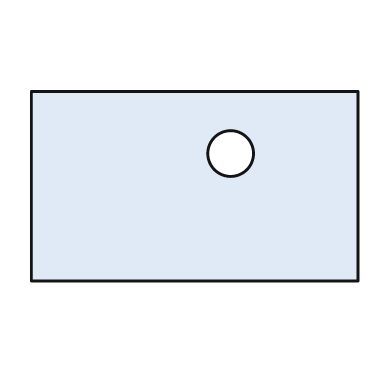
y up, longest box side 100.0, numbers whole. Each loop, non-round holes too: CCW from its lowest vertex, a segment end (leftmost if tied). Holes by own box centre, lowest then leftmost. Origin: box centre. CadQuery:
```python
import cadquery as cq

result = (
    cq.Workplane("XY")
    .moveTo(-50.0, -29.0)
    .lineTo(50.0, -29.0)
    .lineTo(50.0, 29.0)
    .lineTo(-50.0, 29.0)
    .close()
    .moveTo(11.0, 10.0)
    .circle(7.0)
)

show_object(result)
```